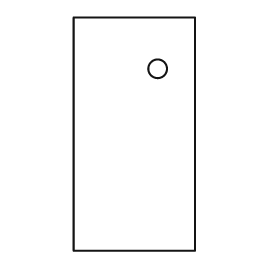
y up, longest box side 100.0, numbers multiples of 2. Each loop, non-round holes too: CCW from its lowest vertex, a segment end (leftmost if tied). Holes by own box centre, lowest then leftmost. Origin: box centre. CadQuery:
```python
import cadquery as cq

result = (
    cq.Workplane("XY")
    .moveTo(-26.0, -50.0)
    .lineTo(26.0, -50.0)
    .lineTo(26.0, 50.0)
    .lineTo(-26.0, 50.0)
    .close()
    .moveTo(10.0, 28.0)
    .circle(4.0)
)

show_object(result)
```